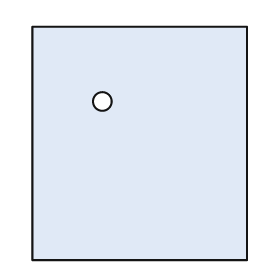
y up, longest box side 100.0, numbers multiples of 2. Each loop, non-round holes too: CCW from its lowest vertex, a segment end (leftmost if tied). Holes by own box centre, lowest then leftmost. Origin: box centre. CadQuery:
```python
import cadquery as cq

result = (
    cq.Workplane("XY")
    .moveTo(-46.0, -50.0)
    .lineTo(46.0, -50.0)
    .lineTo(46.0, 50.0)
    .lineTo(-46.0, 50.0)
    .close()
    .moveTo(-16.0, 18.0)
    .circle(4.0)
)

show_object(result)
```